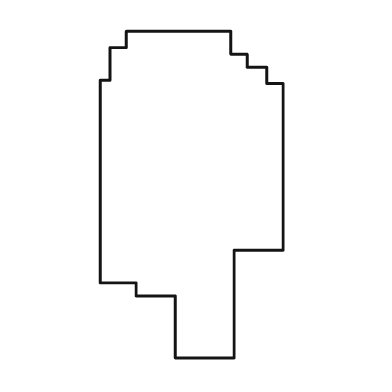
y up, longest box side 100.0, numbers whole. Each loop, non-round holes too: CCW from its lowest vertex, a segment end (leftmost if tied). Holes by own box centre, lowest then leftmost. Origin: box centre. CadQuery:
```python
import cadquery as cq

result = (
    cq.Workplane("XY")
    .moveTo(-5.0, -50.0)
    .lineTo(13.0, -50.0)
    .lineTo(13.0, -17.0)
    .lineTo(28.0, -17.0)
    .lineTo(28.0, 34.0)
    .lineTo(23.0, 34.0)
    .lineTo(23.0, 39.0)
    .lineTo(17.0, 39.0)
    .lineTo(17.0, 43.0)
    .lineTo(12.0, 43.0)
    .lineTo(12.0, 50.0)
    .lineTo(-20.0, 50.0)
    .lineTo(-20.0, 45.0)
    .lineTo(-25.0, 45.0)
    .lineTo(-25.0, 35.0)
    .lineTo(-28.0, 35.0)
    .lineTo(-28.0, -27.0)
    .lineTo(-17.0, -27.0)
    .lineTo(-17.0, -31.0)
    .lineTo(-5.0, -31.0)
    .close()
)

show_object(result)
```